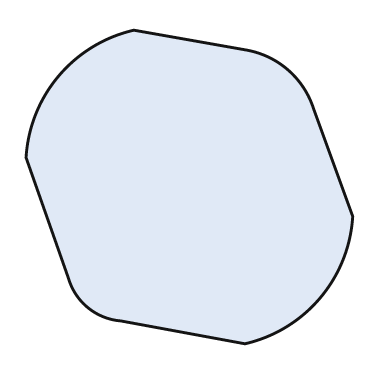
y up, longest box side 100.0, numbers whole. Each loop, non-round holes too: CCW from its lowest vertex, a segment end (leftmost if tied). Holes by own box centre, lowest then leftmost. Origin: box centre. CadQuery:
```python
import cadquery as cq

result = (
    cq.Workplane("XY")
    .moveTo(17.0, -48.0)
    .threePointArc((40.0, -34.0), (50.0, -9.0))
    .lineTo(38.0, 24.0)
    .threePointArc((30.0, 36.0), (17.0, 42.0))
    .lineTo(-17.0, 48.0)
    .threePointArc((-40.0, 34.0), (-50.0, 9.0))
    .lineTo(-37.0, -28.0)
    .threePointArc((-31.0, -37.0), (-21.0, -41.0))
    .close()
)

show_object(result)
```